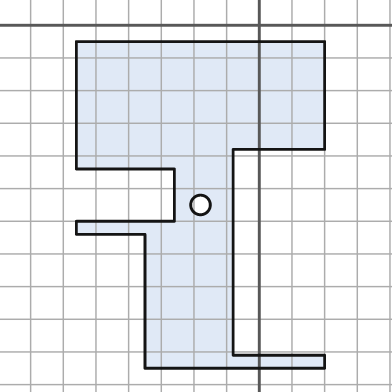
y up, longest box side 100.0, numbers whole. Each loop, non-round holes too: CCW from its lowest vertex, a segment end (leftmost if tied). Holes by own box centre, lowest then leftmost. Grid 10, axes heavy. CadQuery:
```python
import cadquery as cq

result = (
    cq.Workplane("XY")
    .moveTo(-35.0, -105.0)
    .lineTo(20.0, -105.0)
    .lineTo(20.0, -101.0)
    .lineTo(-8.0, -101.0)
    .lineTo(-8.0, -38.0)
    .lineTo(20.0, -38.0)
    .lineTo(20.0, -5.0)
    .lineTo(-56.0, -5.0)
    .lineTo(-56.0, -44.0)
    .lineTo(-26.0, -44.0)
    .lineTo(-26.0, -60.0)
    .lineTo(-56.0, -60.0)
    .lineTo(-56.0, -64.0)
    .lineTo(-35.0, -64.0)
    .close()
    .moveTo(-18.0, -55.0)
    .circle(3.0)
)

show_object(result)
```